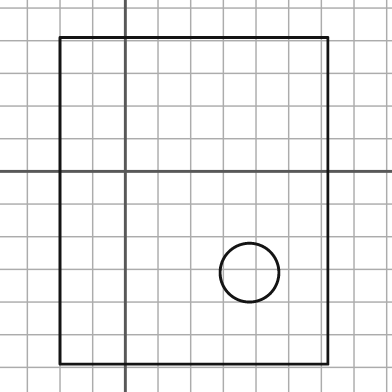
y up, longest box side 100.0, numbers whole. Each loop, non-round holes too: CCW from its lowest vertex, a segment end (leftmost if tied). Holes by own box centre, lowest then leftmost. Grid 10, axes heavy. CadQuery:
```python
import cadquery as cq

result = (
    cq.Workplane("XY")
    .moveTo(-20.0, -59.0)
    .lineTo(62.0, -59.0)
    .lineTo(62.0, 41.0)
    .lineTo(-20.0, 41.0)
    .close()
    .moveTo(38.0, -31.0)
    .circle(9.0)
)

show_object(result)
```